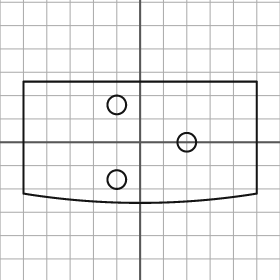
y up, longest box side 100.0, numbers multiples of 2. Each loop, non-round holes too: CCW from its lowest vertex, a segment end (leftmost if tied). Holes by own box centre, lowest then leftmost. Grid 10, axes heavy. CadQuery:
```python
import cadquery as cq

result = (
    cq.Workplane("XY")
    .moveTo(-50.0, -22.0)
    .threePointArc((0.0, -26.0), (50.0, -22.0))
    .lineTo(50.0, 26.0)
    .lineTo(-50.0, 26.0)
    .close()
    .moveTo(-10.0, -16.0)
    .circle(4.0)
    .moveTo(20.0, 0.0)
    .circle(4.0)
    .moveTo(-10.0, 16.0)
    .circle(4.0)
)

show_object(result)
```